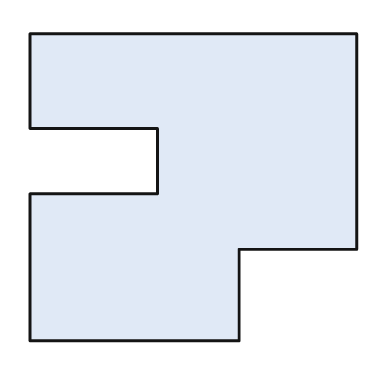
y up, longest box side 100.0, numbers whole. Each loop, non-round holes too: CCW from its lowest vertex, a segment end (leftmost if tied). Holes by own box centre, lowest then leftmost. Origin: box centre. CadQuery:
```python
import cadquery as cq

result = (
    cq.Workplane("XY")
    .moveTo(-50.0, -47.0)
    .lineTo(14.0, -47.0)
    .lineTo(14.0, -19.0)
    .lineTo(50.0, -19.0)
    .lineTo(50.0, 47.0)
    .lineTo(-50.0, 47.0)
    .lineTo(-50.0, 18.0)
    .lineTo(-11.0, 18.0)
    .lineTo(-11.0, -2.0)
    .lineTo(-50.0, -2.0)
    .close()
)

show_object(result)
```